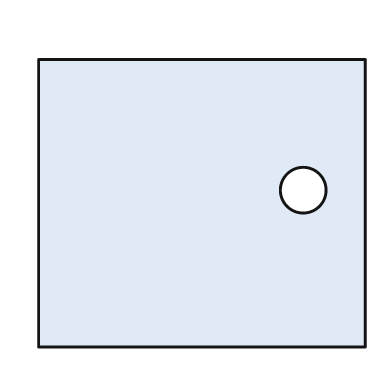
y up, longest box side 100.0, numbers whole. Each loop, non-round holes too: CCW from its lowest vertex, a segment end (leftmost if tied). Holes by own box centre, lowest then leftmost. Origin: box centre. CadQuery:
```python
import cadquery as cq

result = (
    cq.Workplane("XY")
    .moveTo(-50.0, -44.0)
    .lineTo(50.0, -44.0)
    .lineTo(50.0, 44.0)
    .lineTo(-50.0, 44.0)
    .close()
    .moveTo(31.0, 4.0)
    .circle(7.0)
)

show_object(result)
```